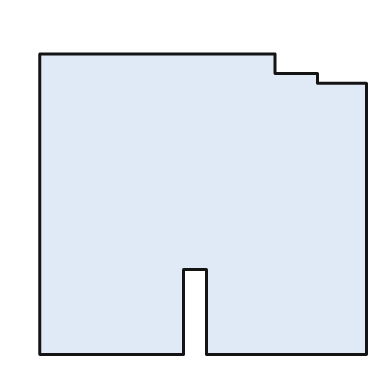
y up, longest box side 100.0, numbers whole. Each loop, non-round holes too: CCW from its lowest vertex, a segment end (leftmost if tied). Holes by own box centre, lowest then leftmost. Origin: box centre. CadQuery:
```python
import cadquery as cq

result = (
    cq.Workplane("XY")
    .moveTo(-50.0, -46.0)
    .lineTo(-6.0, -46.0)
    .lineTo(-6.0, -20.0)
    .lineTo(1.0, -20.0)
    .lineTo(1.0, -46.0)
    .lineTo(50.0, -46.0)
    .lineTo(50.0, 37.0)
    .lineTo(35.0, 37.0)
    .lineTo(35.0, 40.0)
    .lineTo(22.0, 40.0)
    .lineTo(22.0, 46.0)
    .lineTo(-50.0, 46.0)
    .close()
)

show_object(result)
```